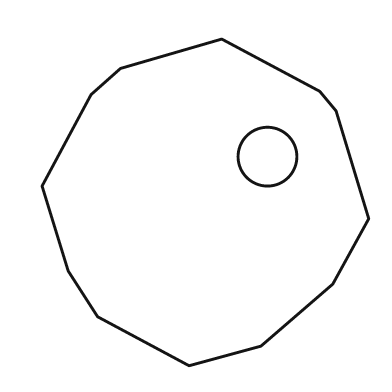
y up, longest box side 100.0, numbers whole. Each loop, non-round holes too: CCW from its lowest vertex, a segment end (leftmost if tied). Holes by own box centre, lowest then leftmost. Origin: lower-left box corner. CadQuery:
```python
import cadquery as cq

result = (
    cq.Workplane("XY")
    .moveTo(45.0, 0.0)
    .lineTo(67.0, 6.0)
    .lineTo(89.0, 25.0)
    .lineTo(100.0, 45.0)
    .lineTo(90.0, 78.0)
    .lineTo(85.0, 84.0)
    .lineTo(55.0, 100.0)
    .lineTo(24.0, 91.0)
    .lineTo(15.0, 83.0)
    .lineTo(0.0, 55.0)
    .lineTo(8.0, 29.0)
    .lineTo(17.0, 15.0)
    .close()
    .moveTo(69.0, 64.0)
    .circle(9.0)
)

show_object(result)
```